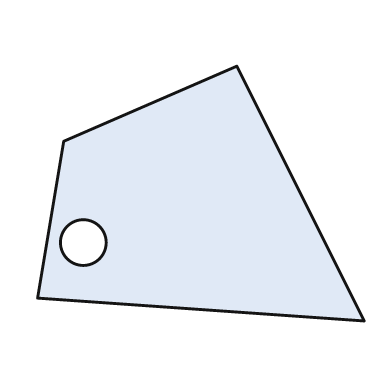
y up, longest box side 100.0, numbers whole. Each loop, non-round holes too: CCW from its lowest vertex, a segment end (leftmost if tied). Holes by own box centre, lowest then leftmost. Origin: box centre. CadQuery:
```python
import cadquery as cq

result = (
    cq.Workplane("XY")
    .moveTo(50.0, -39.0)
    .lineTo(11.0, 39.0)
    .lineTo(-42.0, 16.0)
    .lineTo(-50.0, -32.0)
    .close()
    .moveTo(-36.0, -15.0)
    .circle(7.0)
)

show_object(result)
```